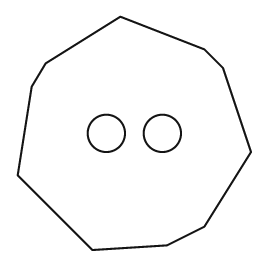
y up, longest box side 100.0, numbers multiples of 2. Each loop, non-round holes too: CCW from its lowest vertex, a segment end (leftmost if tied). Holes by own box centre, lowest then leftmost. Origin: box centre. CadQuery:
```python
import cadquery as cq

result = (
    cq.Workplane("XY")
    .moveTo(-18.0, -50.0)
    .lineTo(14.0, -48.0)
    .lineTo(30.0, -40.0)
    .lineTo(50.0, -8.0)
    .lineTo(38.0, 28.0)
    .lineTo(30.0, 36.0)
    .lineTo(-6.0, 50.0)
    .lineTo(-38.0, 30.0)
    .lineTo(-44.0, 20.0)
    .lineTo(-50.0, -18.0)
    .close()
    .moveTo(-12.0, 0.0)
    .circle(8.0)
    .moveTo(12.0, 0.0)
    .circle(8.0)
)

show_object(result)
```